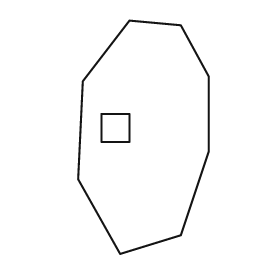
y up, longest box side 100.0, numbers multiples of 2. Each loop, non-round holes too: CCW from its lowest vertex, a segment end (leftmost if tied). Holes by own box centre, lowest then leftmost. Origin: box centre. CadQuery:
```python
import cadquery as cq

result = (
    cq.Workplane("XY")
    .moveTo(-10.0, -50.0)
    .lineTo(16.0, -42.0)
    .lineTo(28.0, -6.0)
    .lineTo(28.0, 26.0)
    .lineTo(16.0, 48.0)
    .lineTo(-6.0, 50.0)
    .lineTo(-26.0, 24.0)
    .lineTo(-28.0, -18.0)
    .close()
    .moveTo(-18.0, -2.0)
    .lineTo(-6.0, -2.0)
    .lineTo(-6.0, 10.0)
    .lineTo(-18.0, 10.0)
    .close()
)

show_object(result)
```